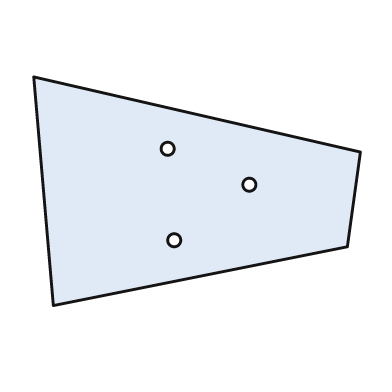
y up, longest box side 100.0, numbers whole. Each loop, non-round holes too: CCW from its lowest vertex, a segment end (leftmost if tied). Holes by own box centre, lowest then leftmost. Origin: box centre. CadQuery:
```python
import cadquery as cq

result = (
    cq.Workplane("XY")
    .moveTo(-44.0, -35.0)
    .lineTo(46.0, -17.0)
    .lineTo(50.0, 12.0)
    .lineTo(-50.0, 35.0)
    .close()
    .moveTo(-7.0, -15.0)
    .circle(2.0)
    .moveTo(16.0, 2.0)
    .circle(2.0)
    .moveTo(-9.0, 13.0)
    .circle(2.0)
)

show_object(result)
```